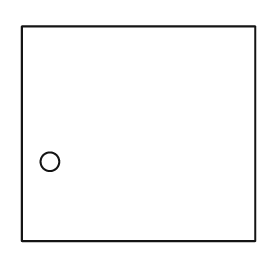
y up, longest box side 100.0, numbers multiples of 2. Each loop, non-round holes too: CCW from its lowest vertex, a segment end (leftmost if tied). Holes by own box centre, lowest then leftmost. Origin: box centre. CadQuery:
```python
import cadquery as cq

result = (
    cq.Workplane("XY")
    .moveTo(-50.0, -46.0)
    .lineTo(50.0, -46.0)
    .lineTo(50.0, 46.0)
    .lineTo(-50.0, 46.0)
    .close()
    .moveTo(-38.0, -12.0)
    .circle(4.0)
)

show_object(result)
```